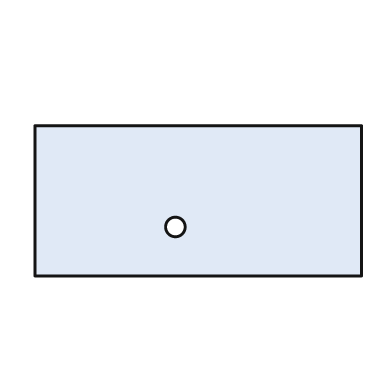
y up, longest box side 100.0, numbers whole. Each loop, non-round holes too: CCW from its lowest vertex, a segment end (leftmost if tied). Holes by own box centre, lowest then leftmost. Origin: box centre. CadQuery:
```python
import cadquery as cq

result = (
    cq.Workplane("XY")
    .moveTo(-50.0, -23.0)
    .lineTo(50.0, -23.0)
    .lineTo(50.0, 23.0)
    .lineTo(-50.0, 23.0)
    .close()
    .moveTo(-7.0, -8.0)
    .circle(3.0)
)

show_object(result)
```